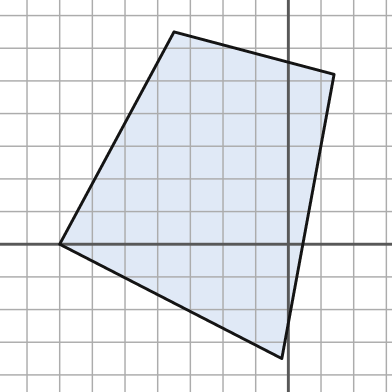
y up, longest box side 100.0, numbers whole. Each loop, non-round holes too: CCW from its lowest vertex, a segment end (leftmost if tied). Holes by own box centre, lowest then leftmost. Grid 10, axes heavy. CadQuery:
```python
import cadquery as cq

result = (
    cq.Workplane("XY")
    .moveTo(-2.0, -35.0)
    .lineTo(14.0, 52.0)
    .lineTo(-35.0, 65.0)
    .lineTo(-70.0, 0.0)
    .close()
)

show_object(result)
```